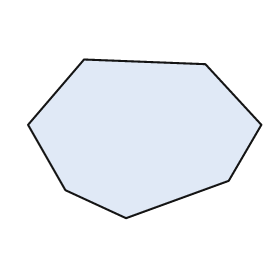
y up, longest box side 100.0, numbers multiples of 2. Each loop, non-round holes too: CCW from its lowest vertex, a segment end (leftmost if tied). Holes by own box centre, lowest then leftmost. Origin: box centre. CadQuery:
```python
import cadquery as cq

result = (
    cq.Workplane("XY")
    .moveTo(-8.0, -34.0)
    .lineTo(36.0, -18.0)
    .lineTo(50.0, 6.0)
    .lineTo(26.0, 32.0)
    .lineTo(-26.0, 34.0)
    .lineTo(-50.0, 6.0)
    .lineTo(-34.0, -22.0)
    .close()
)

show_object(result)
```